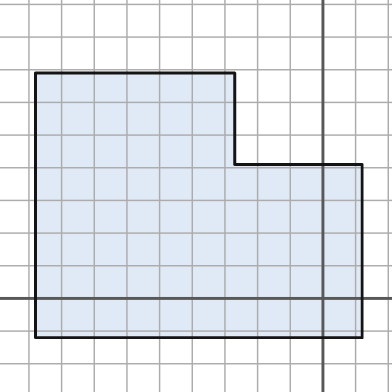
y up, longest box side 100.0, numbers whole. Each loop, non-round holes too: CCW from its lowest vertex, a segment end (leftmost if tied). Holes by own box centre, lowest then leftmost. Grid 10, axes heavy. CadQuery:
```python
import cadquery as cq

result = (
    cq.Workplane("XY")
    .moveTo(-88.0, -12.0)
    .lineTo(12.0, -12.0)
    .lineTo(12.0, 41.0)
    .lineTo(-27.0, 41.0)
    .lineTo(-27.0, 69.0)
    .lineTo(-88.0, 69.0)
    .close()
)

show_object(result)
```